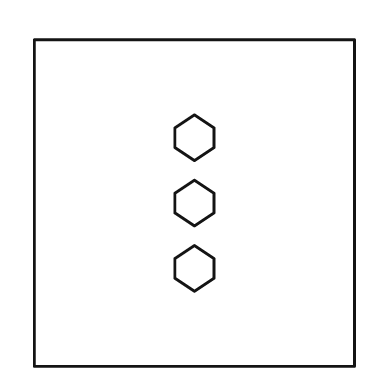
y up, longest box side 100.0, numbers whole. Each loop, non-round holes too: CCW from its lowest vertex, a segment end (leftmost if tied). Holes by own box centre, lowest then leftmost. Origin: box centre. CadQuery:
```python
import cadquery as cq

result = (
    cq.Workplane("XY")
    .moveTo(-49.0, -50.0)
    .lineTo(49.0, -50.0)
    .lineTo(49.0, 50.0)
    .lineTo(-49.0, 50.0)
    .close()
    .moveTo(0.0, -27.0)
    .lineTo(6.0, -23.0)
    .lineTo(6.0, -17.0)
    .lineTo(0.0, -13.0)
    .lineTo(-6.0, -17.0)
    .lineTo(-6.0, -23.0)
    .close()
    .moveTo(0.0, -7.0)
    .lineTo(6.0, -3.0)
    .lineTo(6.0, 3.0)
    .lineTo(0.0, 7.0)
    .lineTo(-6.0, 3.0)
    .lineTo(-6.0, -3.0)
    .close()
    .moveTo(0.0, 13.0)
    .lineTo(6.0, 17.0)
    .lineTo(6.0, 23.0)
    .lineTo(0.0, 27.0)
    .lineTo(-6.0, 23.0)
    .lineTo(-6.0, 17.0)
    .close()
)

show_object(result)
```